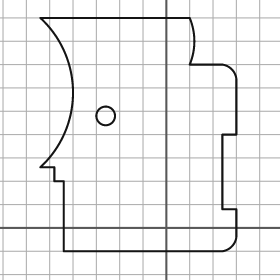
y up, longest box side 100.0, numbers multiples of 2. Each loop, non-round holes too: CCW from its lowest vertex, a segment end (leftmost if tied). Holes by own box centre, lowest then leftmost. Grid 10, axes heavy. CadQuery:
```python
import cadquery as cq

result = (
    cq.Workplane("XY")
    .moveTo(-44.0, -10.0)
    .lineTo(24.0, -10.0)
    .threePointArc((28.0, -8.0), (30.0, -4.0))
    .lineTo(30.0, 8.0)
    .lineTo(24.0, 8.0)
    .lineTo(24.0, 40.0)
    .lineTo(30.0, 40.0)
    .lineTo(30.0, 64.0)
    .threePointArc((28.0, 68.0), (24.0, 70.0))
    .lineTo(10.0, 70.0)
    .threePointArc((12.0, 80.0), (10.0, 90.0))
    .lineTo(-54.0, 90.0)
    .threePointArc((-40.0, 58.0), (-54.0, 26.0))
    .lineTo(-48.0, 26.0)
    .lineTo(-48.0, 20.0)
    .lineTo(-44.0, 20.0)
    .close()
    .moveTo(-26.0, 48.0)
    .circle(4.0)
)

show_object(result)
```